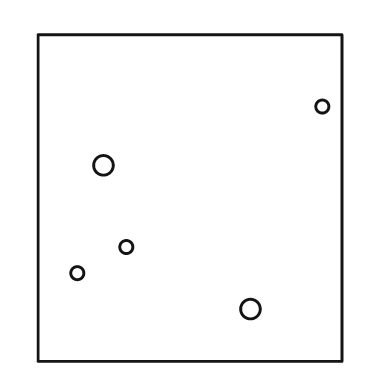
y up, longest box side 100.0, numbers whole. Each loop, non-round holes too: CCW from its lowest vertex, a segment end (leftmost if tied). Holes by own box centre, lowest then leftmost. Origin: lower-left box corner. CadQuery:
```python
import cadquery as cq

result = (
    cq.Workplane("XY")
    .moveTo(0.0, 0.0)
    .lineTo(93.0, 0.0)
    .lineTo(93.0, 100.0)
    .lineTo(0.0, 100.0)
    .close()
    .moveTo(65.0, 16.0)
    .circle(3.0)
    .moveTo(12.0, 27.0)
    .circle(2.0)
    .moveTo(27.0, 35.0)
    .circle(2.0)
    .moveTo(20.0, 60.0)
    .circle(3.0)
    .moveTo(87.0, 78.0)
    .circle(2.0)
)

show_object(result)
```